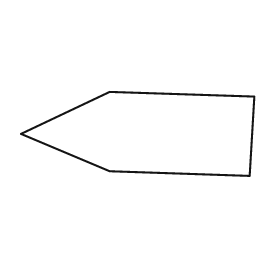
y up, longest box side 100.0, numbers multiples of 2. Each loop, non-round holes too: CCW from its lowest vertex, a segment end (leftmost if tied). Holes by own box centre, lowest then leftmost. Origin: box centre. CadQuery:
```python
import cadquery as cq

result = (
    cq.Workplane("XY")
    .moveTo(48.0, -18.0)
    .lineTo(50.0, 16.0)
    .lineTo(-12.0, 18.0)
    .lineTo(-50.0, 0.0)
    .lineTo(-12.0, -16.0)
    .close()
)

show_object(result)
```